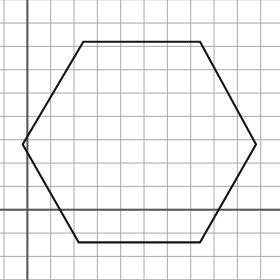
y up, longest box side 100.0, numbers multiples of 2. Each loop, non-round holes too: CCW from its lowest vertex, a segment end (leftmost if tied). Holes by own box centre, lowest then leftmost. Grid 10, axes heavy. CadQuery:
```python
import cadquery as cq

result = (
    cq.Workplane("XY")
    .moveTo(22.0, -14.0)
    .lineTo(74.0, -14.0)
    .lineTo(98.0, 28.0)
    .lineTo(74.0, 72.0)
    .lineTo(24.0, 72.0)
    .lineTo(-2.0, 28.0)
    .close()
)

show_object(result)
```